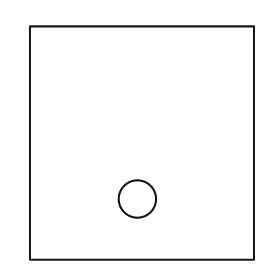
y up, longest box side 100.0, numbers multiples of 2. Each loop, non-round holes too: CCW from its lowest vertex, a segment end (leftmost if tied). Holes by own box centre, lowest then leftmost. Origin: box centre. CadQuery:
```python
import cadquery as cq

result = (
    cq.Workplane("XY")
    .moveTo(-48.0, -50.0)
    .lineTo(48.0, -50.0)
    .lineTo(48.0, 50.0)
    .lineTo(-48.0, 50.0)
    .close()
    .moveTo(-2.0, -24.0)
    .circle(8.0)
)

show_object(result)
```